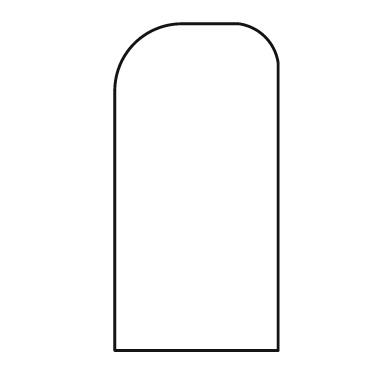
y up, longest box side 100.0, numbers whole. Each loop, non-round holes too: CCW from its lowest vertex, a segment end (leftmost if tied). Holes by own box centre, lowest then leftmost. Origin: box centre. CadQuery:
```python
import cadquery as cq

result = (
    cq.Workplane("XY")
    .moveTo(-25.0, -50.0)
    .lineTo(25.0, -50.0)
    .lineTo(25.0, 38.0)
    .threePointArc((21.0, 46.0), (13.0, 50.0))
    .lineTo(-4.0, 50.0)
    .threePointArc((-19.0, 44.0), (-25.0, 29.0))
    .close()
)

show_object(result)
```